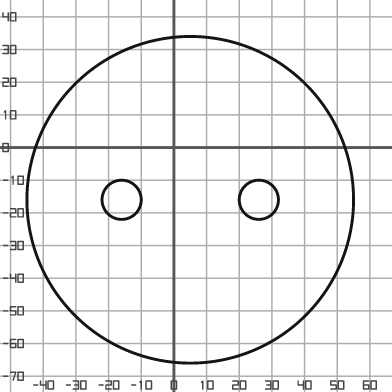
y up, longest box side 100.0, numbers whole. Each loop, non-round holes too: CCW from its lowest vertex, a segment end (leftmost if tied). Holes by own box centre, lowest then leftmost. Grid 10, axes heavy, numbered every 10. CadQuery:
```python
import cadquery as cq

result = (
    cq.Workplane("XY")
    .moveTo(5.0, -16.0)
    .circle(50.0)
    .moveTo(-16.0, -16.0)
    .circle(6.0)
    .moveTo(26.0, -16.0)
    .circle(6.0)
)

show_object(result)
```